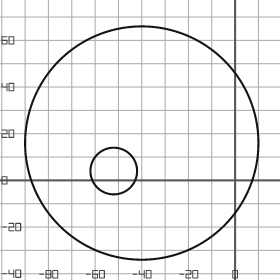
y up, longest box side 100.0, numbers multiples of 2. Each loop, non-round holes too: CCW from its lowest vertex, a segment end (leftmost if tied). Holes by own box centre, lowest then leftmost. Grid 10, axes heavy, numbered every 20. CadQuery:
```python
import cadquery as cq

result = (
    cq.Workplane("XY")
    .moveTo(-40.0, 16.0)
    .circle(50.0)
    .moveTo(-52.0, 4.0)
    .circle(10.0)
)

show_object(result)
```